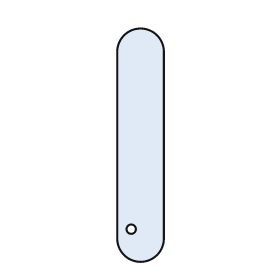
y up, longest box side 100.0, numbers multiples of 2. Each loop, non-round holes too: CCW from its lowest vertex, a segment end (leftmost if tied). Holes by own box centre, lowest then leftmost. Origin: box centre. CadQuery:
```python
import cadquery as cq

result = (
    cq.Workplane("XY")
    .moveTo(-10.0, -40.0)
    .threePointArc((0.0, -50.0), (10.0, -40.0))
    .lineTo(10.0, 40.0)
    .threePointArc((0.0, 50.0), (-10.0, 40.0))
    .close()
    .moveTo(-4.0, -36.0)
    .circle(2.0)
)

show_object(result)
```